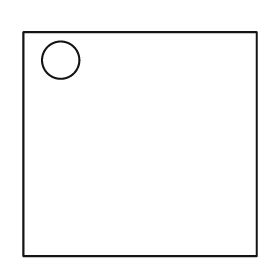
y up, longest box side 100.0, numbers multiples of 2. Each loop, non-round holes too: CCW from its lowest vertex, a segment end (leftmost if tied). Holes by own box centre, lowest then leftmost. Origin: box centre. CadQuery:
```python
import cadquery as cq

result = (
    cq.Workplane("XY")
    .moveTo(-50.0, -48.0)
    .lineTo(50.0, -48.0)
    .lineTo(50.0, 48.0)
    .lineTo(-50.0, 48.0)
    .close()
    .moveTo(-34.0, 36.0)
    .circle(8.0)
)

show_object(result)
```